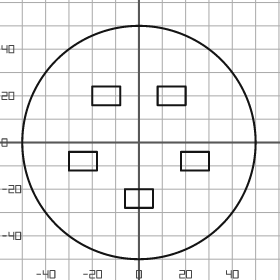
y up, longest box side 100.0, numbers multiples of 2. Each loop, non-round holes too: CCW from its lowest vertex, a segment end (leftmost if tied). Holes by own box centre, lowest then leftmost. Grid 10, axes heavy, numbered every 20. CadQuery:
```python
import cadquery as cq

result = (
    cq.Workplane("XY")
    .moveTo(0.0, 0.0)
    .circle(50.0)
    .moveTo(-6.0, -28.0)
    .lineTo(6.0, -28.0)
    .lineTo(6.0, -20.0)
    .lineTo(-6.0, -20.0)
    .close()
    .moveTo(-30.0, -12.0)
    .lineTo(-18.0, -12.0)
    .lineTo(-18.0, -4.0)
    .lineTo(-30.0, -4.0)
    .close()
    .moveTo(18.0, -12.0)
    .lineTo(30.0, -12.0)
    .lineTo(30.0, -4.0)
    .lineTo(18.0, -4.0)
    .close()
    .moveTo(-20.0, 16.0)
    .lineTo(-8.0, 16.0)
    .lineTo(-8.0, 24.0)
    .lineTo(-20.0, 24.0)
    .close()
    .moveTo(8.0, 16.0)
    .lineTo(20.0, 16.0)
    .lineTo(20.0, 24.0)
    .lineTo(8.0, 24.0)
    .close()
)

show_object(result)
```